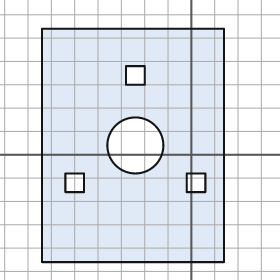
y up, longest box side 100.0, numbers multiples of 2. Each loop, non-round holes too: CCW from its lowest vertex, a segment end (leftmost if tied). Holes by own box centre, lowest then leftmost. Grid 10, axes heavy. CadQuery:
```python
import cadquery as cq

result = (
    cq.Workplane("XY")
    .moveTo(-64.0, -46.0)
    .lineTo(14.0, -46.0)
    .lineTo(14.0, 54.0)
    .lineTo(-64.0, 54.0)
    .close()
    .moveTo(-54.0, -16.0)
    .lineTo(-46.0, -16.0)
    .lineTo(-46.0, -8.0)
    .lineTo(-54.0, -8.0)
    .close()
    .moveTo(-2.0, -16.0)
    .lineTo(6.0, -16.0)
    .lineTo(6.0, -8.0)
    .lineTo(-2.0, -8.0)
    .close()
    .moveTo(-24.0, 4.0)
    .circle(12.0)
    .moveTo(-28.0, 30.0)
    .lineTo(-20.0, 30.0)
    .lineTo(-20.0, 38.0)
    .lineTo(-28.0, 38.0)
    .close()
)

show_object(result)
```